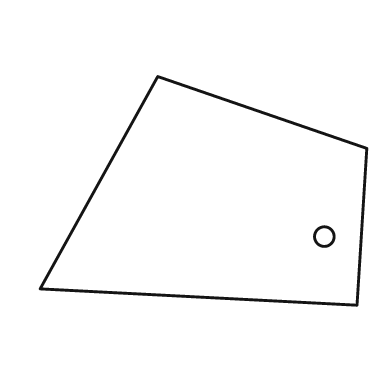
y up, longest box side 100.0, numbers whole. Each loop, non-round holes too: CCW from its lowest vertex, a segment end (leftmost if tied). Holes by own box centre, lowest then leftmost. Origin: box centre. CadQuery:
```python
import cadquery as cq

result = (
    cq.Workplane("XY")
    .moveTo(47.0, -35.0)
    .lineTo(50.0, 13.0)
    .lineTo(-14.0, 35.0)
    .lineTo(-50.0, -30.0)
    .close()
    .moveTo(37.0, -14.0)
    .circle(3.0)
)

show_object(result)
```